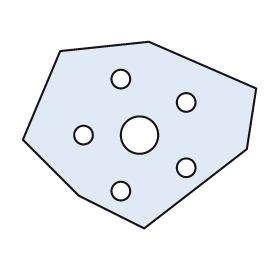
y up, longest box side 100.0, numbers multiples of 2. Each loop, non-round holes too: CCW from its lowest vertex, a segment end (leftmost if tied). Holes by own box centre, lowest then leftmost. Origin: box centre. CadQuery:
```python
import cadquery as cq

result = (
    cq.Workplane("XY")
    .moveTo(2.0, -40.0)
    .lineTo(46.0, -6.0)
    .lineTo(50.0, 20.0)
    .lineTo(4.0, 40.0)
    .lineTo(-34.0, 36.0)
    .lineTo(-50.0, -2.0)
    .lineTo(-26.0, -26.0)
    .close()
    .moveTo(-8.0, -24.0)
    .circle(4.0)
    .moveTo(20.0, -14.0)
    .circle(4.0)
    .moveTo(-24.0, 0.0)
    .circle(4.0)
    .moveTo(0.0, 0.0)
    .circle(8.0)
    .moveTo(20.0, 14.0)
    .circle(4.0)
    .moveTo(-8.0, 24.0)
    .circle(4.0)
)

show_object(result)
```